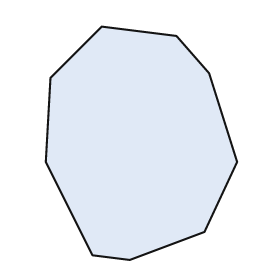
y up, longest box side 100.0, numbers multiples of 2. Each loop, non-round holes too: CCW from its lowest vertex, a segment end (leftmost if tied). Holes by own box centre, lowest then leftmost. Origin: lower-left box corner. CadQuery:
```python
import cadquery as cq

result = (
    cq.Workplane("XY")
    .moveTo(36.0, 0.0)
    .lineTo(68.0, 12.0)
    .lineTo(82.0, 42.0)
    .lineTo(70.0, 80.0)
    .lineTo(56.0, 96.0)
    .lineTo(24.0, 100.0)
    .lineTo(2.0, 78.0)
    .lineTo(0.0, 42.0)
    .lineTo(20.0, 2.0)
    .close()
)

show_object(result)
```